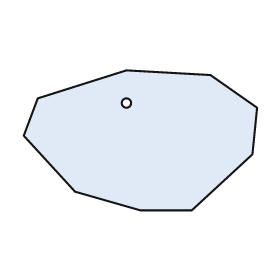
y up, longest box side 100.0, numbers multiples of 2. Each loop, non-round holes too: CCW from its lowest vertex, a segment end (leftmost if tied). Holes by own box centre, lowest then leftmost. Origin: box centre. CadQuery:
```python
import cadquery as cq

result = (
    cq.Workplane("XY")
    .moveTo(0.0, -30.0)
    .lineTo(22.0, -30.0)
    .lineTo(48.0, -6.0)
    .lineTo(50.0, 14.0)
    .lineTo(30.0, 28.0)
    .lineTo(-6.0, 30.0)
    .lineTo(-44.0, 18.0)
    .lineTo(-50.0, 2.0)
    .lineTo(-28.0, -22.0)
    .close()
    .moveTo(-6.0, 16.0)
    .circle(2.0)
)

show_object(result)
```